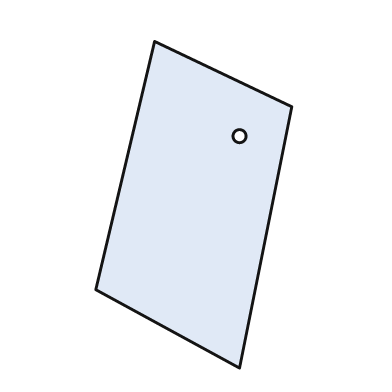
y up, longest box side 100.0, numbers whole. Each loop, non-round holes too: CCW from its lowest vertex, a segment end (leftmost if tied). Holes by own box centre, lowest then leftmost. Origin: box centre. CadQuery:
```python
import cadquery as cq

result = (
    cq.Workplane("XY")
    .moveTo(14.0, -50.0)
    .lineTo(30.0, 30.0)
    .lineTo(-12.0, 50.0)
    .lineTo(-30.0, -26.0)
    .close()
    .moveTo(14.0, 21.0)
    .circle(2.0)
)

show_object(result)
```